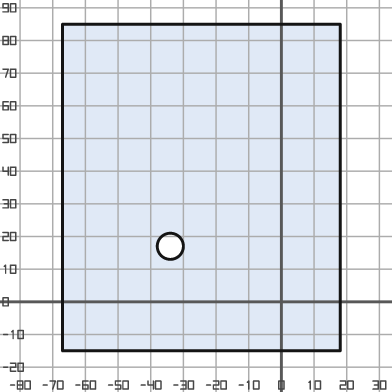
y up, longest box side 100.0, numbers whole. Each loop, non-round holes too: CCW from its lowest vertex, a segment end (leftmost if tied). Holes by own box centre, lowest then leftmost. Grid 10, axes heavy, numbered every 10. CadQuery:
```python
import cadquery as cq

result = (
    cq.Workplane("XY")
    .moveTo(-67.0, -15.0)
    .lineTo(18.0, -15.0)
    .lineTo(18.0, 85.0)
    .lineTo(-67.0, 85.0)
    .close()
    .moveTo(-34.0, 17.0)
    .circle(4.0)
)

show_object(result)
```